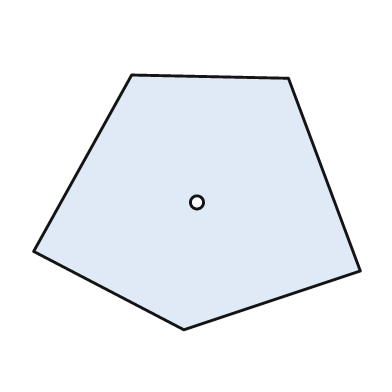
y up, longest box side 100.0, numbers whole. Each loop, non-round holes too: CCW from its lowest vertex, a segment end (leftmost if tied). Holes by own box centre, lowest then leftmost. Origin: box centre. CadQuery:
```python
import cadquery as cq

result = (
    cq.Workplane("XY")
    .moveTo(-4.0, -39.0)
    .lineTo(50.0, -21.0)
    .lineTo(28.0, 38.0)
    .lineTo(-20.0, 39.0)
    .lineTo(-50.0, -15.0)
    .close()
    .moveTo(0.0, 0.0)
    .circle(2.0)
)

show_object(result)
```